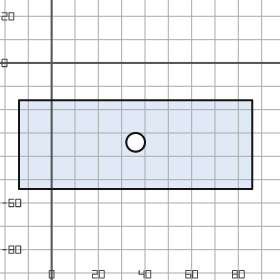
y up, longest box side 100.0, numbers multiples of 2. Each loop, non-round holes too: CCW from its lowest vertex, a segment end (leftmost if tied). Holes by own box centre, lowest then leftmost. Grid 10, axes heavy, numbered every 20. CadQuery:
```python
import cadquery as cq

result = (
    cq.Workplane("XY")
    .moveTo(-14.0, -54.0)
    .lineTo(86.0, -54.0)
    .lineTo(86.0, -16.0)
    .lineTo(-14.0, -16.0)
    .close()
    .moveTo(36.0, -34.0)
    .circle(4.0)
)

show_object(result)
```